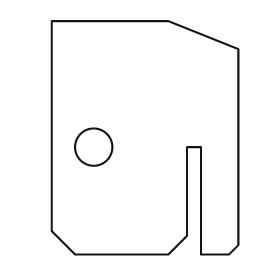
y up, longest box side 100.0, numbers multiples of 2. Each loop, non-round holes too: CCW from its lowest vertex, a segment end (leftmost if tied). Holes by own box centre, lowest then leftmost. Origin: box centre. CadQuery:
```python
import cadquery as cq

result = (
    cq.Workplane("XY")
    .moveTo(-30.0, -50.0)
    .lineTo(10.0, -50.0)
    .lineTo(18.0, -42.0)
    .lineTo(18.0, -4.0)
    .lineTo(24.0, -4.0)
    .lineTo(24.0, -50.0)
    .lineTo(36.0, -50.0)
    .lineTo(40.0, -46.0)
    .lineTo(40.0, 38.0)
    .lineTo(10.0, 50.0)
    .lineTo(-40.0, 50.0)
    .lineTo(-40.0, -40.0)
    .close()
    .moveTo(-22.0, -4.0)
    .circle(8.0)
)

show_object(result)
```